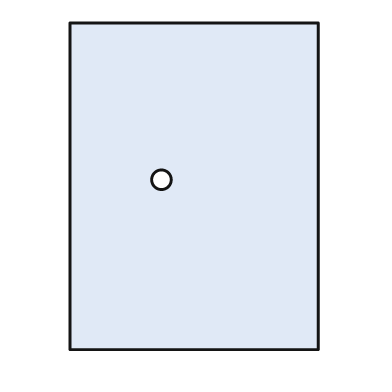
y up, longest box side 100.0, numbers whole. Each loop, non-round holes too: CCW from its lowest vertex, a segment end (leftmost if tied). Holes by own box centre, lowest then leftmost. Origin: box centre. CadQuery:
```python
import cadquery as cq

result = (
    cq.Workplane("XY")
    .moveTo(-38.0, -50.0)
    .lineTo(38.0, -50.0)
    .lineTo(38.0, 50.0)
    .lineTo(-38.0, 50.0)
    .close()
    .moveTo(-10.0, 2.0)
    .circle(3.0)
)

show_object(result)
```